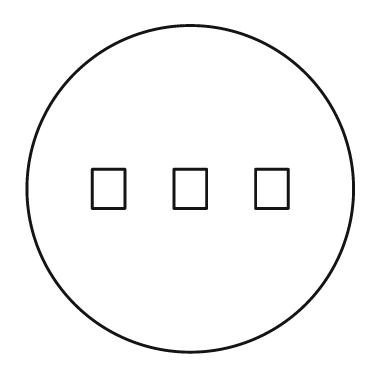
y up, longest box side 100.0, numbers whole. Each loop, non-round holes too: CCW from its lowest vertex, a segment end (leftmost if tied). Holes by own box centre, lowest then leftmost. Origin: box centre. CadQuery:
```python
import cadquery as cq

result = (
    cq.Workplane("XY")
    .moveTo(0.0, 0.0)
    .circle(50.0)
    .moveTo(-30.0, -6.0)
    .lineTo(-20.0, -6.0)
    .lineTo(-20.0, 6.0)
    .lineTo(-30.0, 6.0)
    .close()
    .moveTo(-5.0, -6.0)
    .lineTo(5.0, -6.0)
    .lineTo(5.0, 6.0)
    .lineTo(-5.0, 6.0)
    .close()
    .moveTo(20.0, -6.0)
    .lineTo(30.0, -6.0)
    .lineTo(30.0, 6.0)
    .lineTo(20.0, 6.0)
    .close()
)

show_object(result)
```